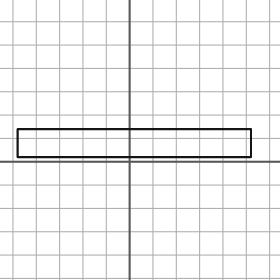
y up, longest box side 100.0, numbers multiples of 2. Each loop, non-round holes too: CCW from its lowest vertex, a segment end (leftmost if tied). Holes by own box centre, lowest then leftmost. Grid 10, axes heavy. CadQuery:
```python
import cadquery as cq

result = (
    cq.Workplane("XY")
    .moveTo(-48.0, 2.0)
    .lineTo(52.0, 2.0)
    .lineTo(52.0, 14.0)
    .lineTo(-48.0, 14.0)
    .close()
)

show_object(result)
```